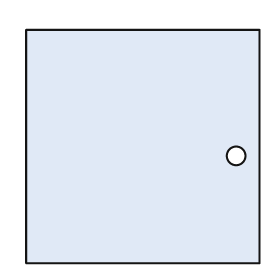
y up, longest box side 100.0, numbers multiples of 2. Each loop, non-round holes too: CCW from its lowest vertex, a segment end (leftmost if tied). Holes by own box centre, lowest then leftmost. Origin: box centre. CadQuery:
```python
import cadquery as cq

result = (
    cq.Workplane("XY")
    .moveTo(-50.0, -50.0)
    .lineTo(50.0, -50.0)
    .lineTo(50.0, 50.0)
    .lineTo(-50.0, 50.0)
    .close()
    .moveTo(40.0, -4.0)
    .circle(4.0)
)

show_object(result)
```